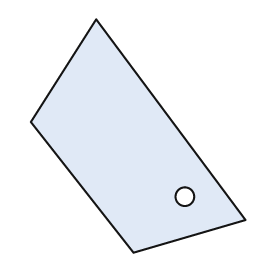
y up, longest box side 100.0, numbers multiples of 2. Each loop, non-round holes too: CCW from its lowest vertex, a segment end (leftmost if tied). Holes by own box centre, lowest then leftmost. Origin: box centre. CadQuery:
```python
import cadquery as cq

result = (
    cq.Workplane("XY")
    .moveTo(-2.0, -50.0)
    .lineTo(46.0, -36.0)
    .lineTo(-18.0, 50.0)
    .lineTo(-46.0, 6.0)
    .close()
    .moveTo(20.0, -26.0)
    .circle(4.0)
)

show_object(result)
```